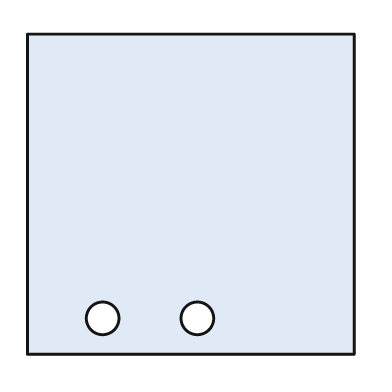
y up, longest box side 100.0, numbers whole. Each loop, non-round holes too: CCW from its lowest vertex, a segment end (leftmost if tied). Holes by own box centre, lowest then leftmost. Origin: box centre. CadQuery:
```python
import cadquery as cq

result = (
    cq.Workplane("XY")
    .moveTo(-50.0, -49.0)
    .lineTo(50.0, -49.0)
    .lineTo(50.0, 49.0)
    .lineTo(-50.0, 49.0)
    .close()
    .moveTo(-27.0, -38.0)
    .circle(5.0)
    .moveTo(2.0, -38.0)
    .circle(5.0)
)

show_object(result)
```